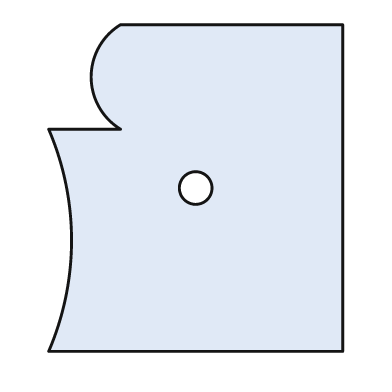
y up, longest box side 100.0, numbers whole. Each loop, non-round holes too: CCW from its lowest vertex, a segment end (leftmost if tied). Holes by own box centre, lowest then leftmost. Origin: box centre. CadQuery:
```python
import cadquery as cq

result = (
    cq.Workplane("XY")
    .moveTo(-45.0, -50.0)
    .lineTo(45.0, -50.0)
    .lineTo(45.0, 50.0)
    .lineTo(-23.0, 50.0)
    .threePointArc((-32.0, 34.0), (-23.0, 18.0))
    .lineTo(-45.0, 18.0)
    .threePointArc((-38.0, -16.0), (-45.0, -50.0))
    .close()
    .moveTo(0.0, 0.0)
    .circle(5.0)
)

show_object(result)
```